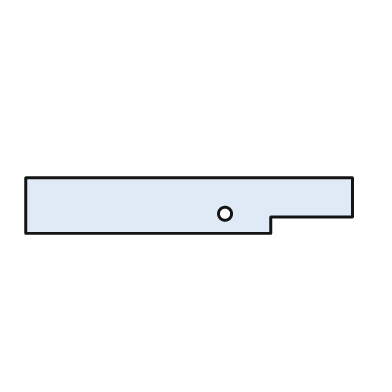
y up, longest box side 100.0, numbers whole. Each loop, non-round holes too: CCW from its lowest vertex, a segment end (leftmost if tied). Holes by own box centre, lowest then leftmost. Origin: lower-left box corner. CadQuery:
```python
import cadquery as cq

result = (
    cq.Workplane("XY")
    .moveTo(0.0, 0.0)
    .lineTo(75.0, 0.0)
    .lineTo(75.0, 5.0)
    .lineTo(100.0, 5.0)
    .lineTo(100.0, 17.0)
    .lineTo(0.0, 17.0)
    .close()
    .moveTo(61.0, 6.0)
    .circle(2.0)
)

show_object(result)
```